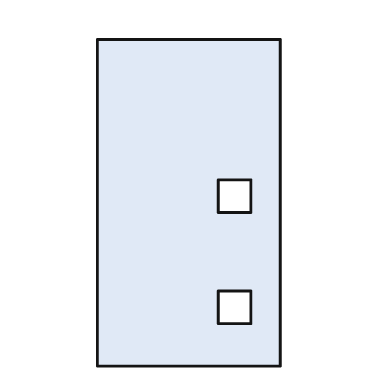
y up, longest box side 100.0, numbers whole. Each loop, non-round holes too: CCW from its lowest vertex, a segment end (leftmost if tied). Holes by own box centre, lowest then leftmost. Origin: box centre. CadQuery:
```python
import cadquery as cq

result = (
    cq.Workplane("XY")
    .moveTo(-28.0, -50.0)
    .lineTo(28.0, -50.0)
    .lineTo(28.0, 50.0)
    .lineTo(-28.0, 50.0)
    .close()
    .moveTo(9.0, -37.0)
    .lineTo(19.0, -37.0)
    .lineTo(19.0, -27.0)
    .lineTo(9.0, -27.0)
    .close()
    .moveTo(9.0, -3.0)
    .lineTo(19.0, -3.0)
    .lineTo(19.0, 7.0)
    .lineTo(9.0, 7.0)
    .close()
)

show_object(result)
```